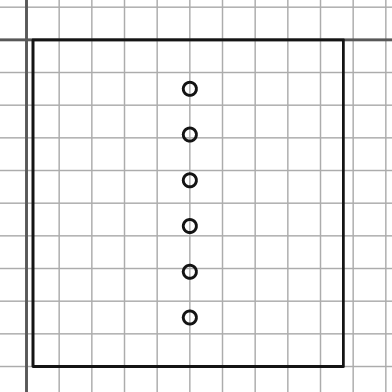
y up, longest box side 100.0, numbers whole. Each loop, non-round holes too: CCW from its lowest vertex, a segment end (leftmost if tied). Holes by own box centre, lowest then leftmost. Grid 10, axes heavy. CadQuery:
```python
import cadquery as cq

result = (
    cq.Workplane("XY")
    .moveTo(2.0, -100.0)
    .lineTo(97.0, -100.0)
    .lineTo(97.0, 0.0)
    .lineTo(2.0, 0.0)
    .close()
    .moveTo(50.0, -85.0)
    .circle(2.0)
    .moveTo(50.0, -71.0)
    .circle(2.0)
    .moveTo(50.0, -57.0)
    .circle(2.0)
    .moveTo(50.0, -43.0)
    .circle(2.0)
    .moveTo(50.0, -29.0)
    .circle(2.0)
    .moveTo(50.0, -15.0)
    .circle(2.0)
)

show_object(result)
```